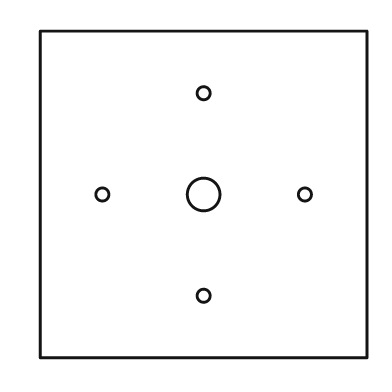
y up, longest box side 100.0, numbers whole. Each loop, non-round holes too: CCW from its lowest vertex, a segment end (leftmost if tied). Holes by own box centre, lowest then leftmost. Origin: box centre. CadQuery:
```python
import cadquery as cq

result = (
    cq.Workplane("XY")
    .moveTo(-50.0, -50.0)
    .lineTo(50.0, -50.0)
    .lineTo(50.0, 50.0)
    .lineTo(-50.0, 50.0)
    .close()
    .moveTo(0.0, -31.0)
    .circle(2.0)
    .moveTo(-31.0, 0.0)
    .circle(2.0)
    .moveTo(0.0, 0.0)
    .circle(5.0)
    .moveTo(31.0, 0.0)
    .circle(2.0)
    .moveTo(0.0, 31.0)
    .circle(2.0)
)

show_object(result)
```